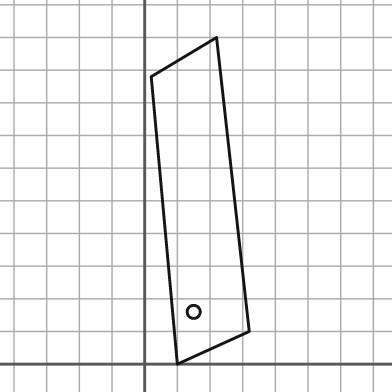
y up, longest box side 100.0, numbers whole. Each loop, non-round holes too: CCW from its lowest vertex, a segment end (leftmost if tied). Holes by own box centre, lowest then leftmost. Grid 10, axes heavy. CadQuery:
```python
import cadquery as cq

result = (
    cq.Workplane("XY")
    .moveTo(10.0, 0.0)
    .lineTo(32.0, 10.0)
    .lineTo(22.0, 100.0)
    .lineTo(2.0, 88.0)
    .close()
    .moveTo(15.0, 16.0)
    .circle(2.0)
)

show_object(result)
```